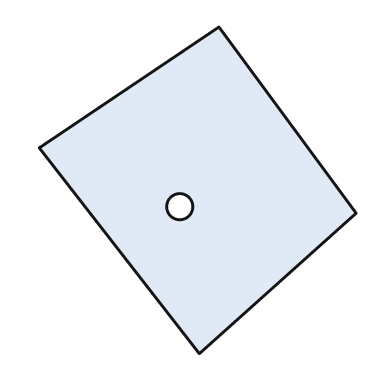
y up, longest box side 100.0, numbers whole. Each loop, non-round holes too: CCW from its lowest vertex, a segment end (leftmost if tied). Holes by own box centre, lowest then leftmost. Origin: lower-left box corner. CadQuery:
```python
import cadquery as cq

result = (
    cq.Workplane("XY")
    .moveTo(49.0, 0.0)
    .lineTo(97.0, 43.0)
    .lineTo(55.0, 100.0)
    .lineTo(0.0, 63.0)
    .close()
    .moveTo(43.0, 45.0)
    .circle(4.0)
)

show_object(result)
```